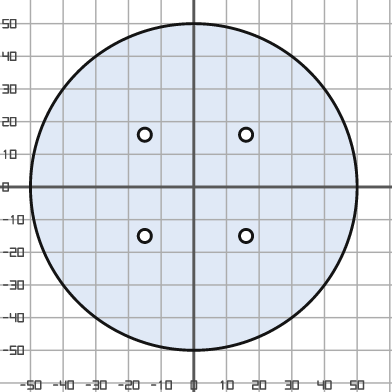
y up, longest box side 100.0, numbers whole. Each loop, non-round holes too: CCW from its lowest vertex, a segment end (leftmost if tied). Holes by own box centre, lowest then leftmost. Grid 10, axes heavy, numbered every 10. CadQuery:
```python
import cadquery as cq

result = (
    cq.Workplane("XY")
    .moveTo(0.0, 0.0)
    .circle(50.0)
    .moveTo(-15.0, -15.0)
    .circle(2.0)
    .moveTo(16.0, -15.0)
    .circle(2.0)
    .moveTo(-15.0, 16.0)
    .circle(2.0)
    .moveTo(16.0, 16.0)
    .circle(2.0)
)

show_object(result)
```